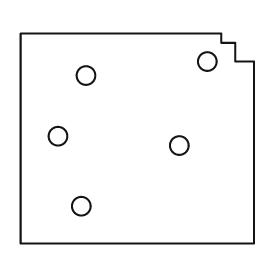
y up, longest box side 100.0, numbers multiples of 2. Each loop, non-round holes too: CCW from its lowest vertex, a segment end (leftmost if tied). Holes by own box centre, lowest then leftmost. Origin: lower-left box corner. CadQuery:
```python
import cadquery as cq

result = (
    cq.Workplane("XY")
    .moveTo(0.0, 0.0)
    .lineTo(100.0, 0.0)
    .lineTo(100.0, 78.0)
    .lineTo(92.0, 78.0)
    .lineTo(92.0, 86.0)
    .lineTo(86.0, 86.0)
    .lineTo(86.0, 90.0)
    .lineTo(0.0, 90.0)
    .close()
    .moveTo(26.0, 16.0)
    .circle(4.0)
    .moveTo(68.0, 42.0)
    .circle(4.0)
    .moveTo(16.0, 46.0)
    .circle(4.0)
    .moveTo(28.0, 72.0)
    .circle(4.0)
    .moveTo(80.0, 78.0)
    .circle(4.0)
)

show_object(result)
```